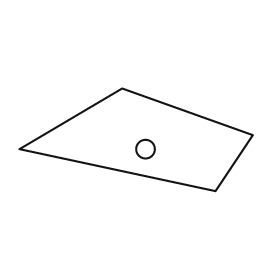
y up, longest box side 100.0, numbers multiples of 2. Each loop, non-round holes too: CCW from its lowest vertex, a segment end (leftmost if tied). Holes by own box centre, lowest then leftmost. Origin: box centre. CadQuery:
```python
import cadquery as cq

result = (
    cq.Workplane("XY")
    .moveTo(34.0, -22.0)
    .lineTo(50.0, 2.0)
    .lineTo(-6.0, 22.0)
    .lineTo(-50.0, -4.0)
    .close()
    .moveTo(4.0, -4.0)
    .circle(4.0)
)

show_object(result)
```